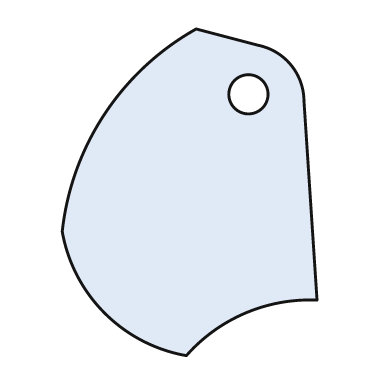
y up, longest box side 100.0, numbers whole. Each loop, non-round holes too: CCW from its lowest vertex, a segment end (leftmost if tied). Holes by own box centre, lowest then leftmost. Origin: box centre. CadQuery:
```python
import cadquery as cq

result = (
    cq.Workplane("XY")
    .moveTo(-1.0, -50.0)
    .threePointArc((17.0, -37.0), (39.0, -33.0))
    .lineTo(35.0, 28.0)
    .threePointArc((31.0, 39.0), (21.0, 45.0))
    .lineTo(2.0, 50.0)
    .threePointArc((-26.0, 24.0), (-39.0, -12.0))
    .threePointArc((-26.0, -37.0), (-1.0, -50.0))
    .close()
    .moveTo(18.0, 30.0)
    .circle(6.0)
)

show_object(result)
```